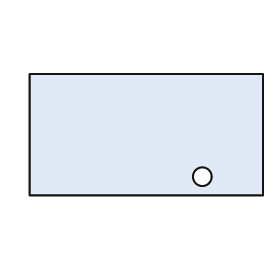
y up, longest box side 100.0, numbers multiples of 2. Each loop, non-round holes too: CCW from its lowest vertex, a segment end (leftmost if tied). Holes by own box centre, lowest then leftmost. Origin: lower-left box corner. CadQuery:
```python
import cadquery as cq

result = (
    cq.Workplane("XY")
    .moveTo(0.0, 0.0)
    .lineTo(100.0, 0.0)
    .lineTo(100.0, 52.0)
    .lineTo(0.0, 52.0)
    .close()
    .moveTo(74.0, 8.0)
    .circle(4.0)
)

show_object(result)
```